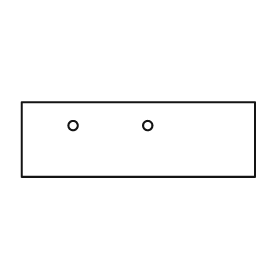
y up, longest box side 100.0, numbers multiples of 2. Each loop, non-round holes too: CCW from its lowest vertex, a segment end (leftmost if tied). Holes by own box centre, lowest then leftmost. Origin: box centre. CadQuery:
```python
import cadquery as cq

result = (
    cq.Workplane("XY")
    .moveTo(-50.0, -16.0)
    .lineTo(50.0, -16.0)
    .lineTo(50.0, 16.0)
    .lineTo(-50.0, 16.0)
    .close()
    .moveTo(-28.0, 6.0)
    .circle(2.0)
    .moveTo(4.0, 6.0)
    .circle(2.0)
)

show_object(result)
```